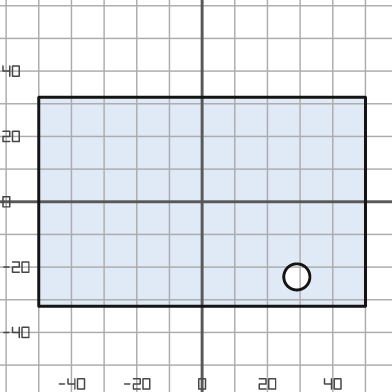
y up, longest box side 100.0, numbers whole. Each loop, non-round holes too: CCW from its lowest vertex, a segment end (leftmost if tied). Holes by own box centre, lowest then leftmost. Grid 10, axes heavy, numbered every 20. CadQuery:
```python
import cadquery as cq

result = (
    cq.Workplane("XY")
    .moveTo(-50.0, -32.0)
    .lineTo(50.0, -32.0)
    .lineTo(50.0, 32.0)
    .lineTo(-50.0, 32.0)
    .close()
    .moveTo(29.0, -23.0)
    .circle(4.0)
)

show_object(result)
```